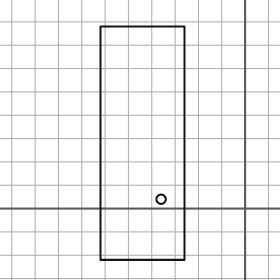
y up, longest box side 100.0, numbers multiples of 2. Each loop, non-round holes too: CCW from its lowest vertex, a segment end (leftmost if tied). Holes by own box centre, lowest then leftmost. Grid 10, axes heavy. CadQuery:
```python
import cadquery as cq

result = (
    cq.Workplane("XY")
    .moveTo(-62.0, -22.0)
    .lineTo(-26.0, -22.0)
    .lineTo(-26.0, 78.0)
    .lineTo(-62.0, 78.0)
    .close()
    .moveTo(-36.0, 4.0)
    .circle(2.0)
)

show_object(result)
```